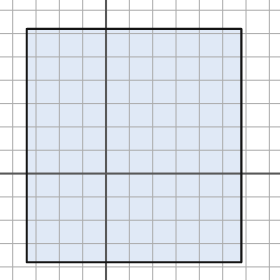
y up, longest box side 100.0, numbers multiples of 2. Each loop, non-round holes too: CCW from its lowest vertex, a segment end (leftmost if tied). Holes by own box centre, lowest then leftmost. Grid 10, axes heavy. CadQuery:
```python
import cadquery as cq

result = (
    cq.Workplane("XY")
    .moveTo(-34.0, -38.0)
    .lineTo(58.0, -38.0)
    .lineTo(58.0, 62.0)
    .lineTo(-34.0, 62.0)
    .close()
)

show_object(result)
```